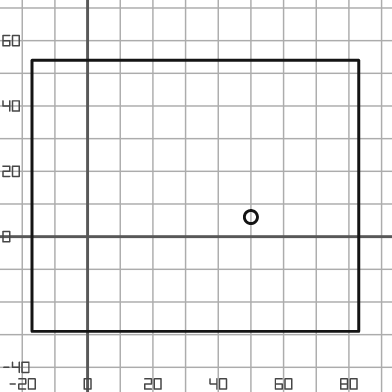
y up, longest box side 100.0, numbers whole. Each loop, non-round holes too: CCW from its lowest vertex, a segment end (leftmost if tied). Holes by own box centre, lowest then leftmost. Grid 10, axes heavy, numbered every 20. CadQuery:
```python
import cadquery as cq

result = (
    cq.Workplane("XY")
    .moveTo(-17.0, -29.0)
    .lineTo(83.0, -29.0)
    .lineTo(83.0, 54.0)
    .lineTo(-17.0, 54.0)
    .close()
    .moveTo(50.0, 6.0)
    .circle(2.0)
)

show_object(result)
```